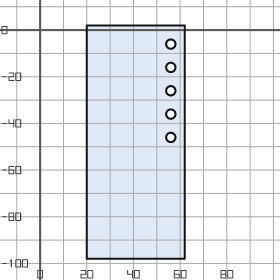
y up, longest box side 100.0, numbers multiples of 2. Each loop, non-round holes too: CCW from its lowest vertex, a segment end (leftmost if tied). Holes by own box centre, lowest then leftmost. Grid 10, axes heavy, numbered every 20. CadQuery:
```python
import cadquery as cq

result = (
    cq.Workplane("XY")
    .moveTo(20.0, -98.0)
    .lineTo(62.0, -98.0)
    .lineTo(62.0, 2.0)
    .lineTo(20.0, 2.0)
    .close()
    .moveTo(56.0, -46.0)
    .circle(2.0)
    .moveTo(56.0, -36.0)
    .circle(2.0)
    .moveTo(56.0, -26.0)
    .circle(2.0)
    .moveTo(56.0, -16.0)
    .circle(2.0)
    .moveTo(56.0, -6.0)
    .circle(2.0)
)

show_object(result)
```